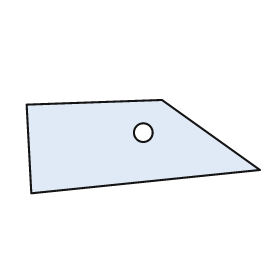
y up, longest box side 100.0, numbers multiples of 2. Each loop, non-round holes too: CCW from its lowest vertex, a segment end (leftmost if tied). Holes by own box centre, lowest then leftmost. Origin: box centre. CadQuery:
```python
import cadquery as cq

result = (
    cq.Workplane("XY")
    .moveTo(-48.0, -20.0)
    .lineTo(50.0, -10.0)
    .lineTo(8.0, 20.0)
    .lineTo(-50.0, 18.0)
    .close()
    .moveTo(0.0, 6.0)
    .circle(4.0)
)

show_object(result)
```